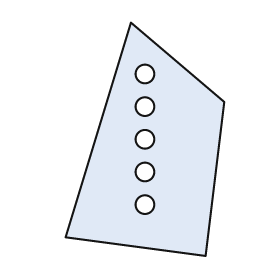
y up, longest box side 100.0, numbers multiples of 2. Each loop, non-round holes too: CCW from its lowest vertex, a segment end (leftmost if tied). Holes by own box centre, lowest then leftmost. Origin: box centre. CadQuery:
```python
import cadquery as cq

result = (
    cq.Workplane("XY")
    .moveTo(26.0, -50.0)
    .lineTo(34.0, 16.0)
    .lineTo(-6.0, 50.0)
    .lineTo(-34.0, -42.0)
    .close()
    .moveTo(0.0, -28.0)
    .circle(4.0)
    .moveTo(0.0, -14.0)
    .circle(4.0)
    .moveTo(0.0, 0.0)
    .circle(4.0)
    .moveTo(0.0, 14.0)
    .circle(4.0)
    .moveTo(0.0, 28.0)
    .circle(4.0)
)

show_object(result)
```